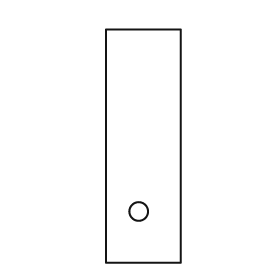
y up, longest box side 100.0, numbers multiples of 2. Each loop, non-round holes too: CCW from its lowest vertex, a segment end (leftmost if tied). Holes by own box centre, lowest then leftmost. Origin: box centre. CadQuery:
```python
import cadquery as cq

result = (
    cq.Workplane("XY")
    .moveTo(-16.0, -50.0)
    .lineTo(16.0, -50.0)
    .lineTo(16.0, 50.0)
    .lineTo(-16.0, 50.0)
    .close()
    .moveTo(-2.0, -28.0)
    .circle(4.0)
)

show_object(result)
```